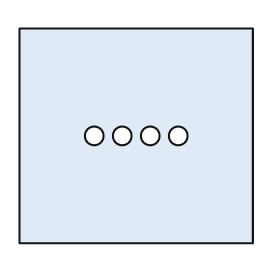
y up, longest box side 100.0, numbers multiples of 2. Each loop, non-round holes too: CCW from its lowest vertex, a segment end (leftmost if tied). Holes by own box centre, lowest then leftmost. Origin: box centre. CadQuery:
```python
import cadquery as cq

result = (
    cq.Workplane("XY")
    .moveTo(-50.0, -46.0)
    .lineTo(50.0, -46.0)
    .lineTo(50.0, 46.0)
    .lineTo(-50.0, 46.0)
    .close()
    .moveTo(-18.0, 0.0)
    .circle(4.0)
    .moveTo(-6.0, 0.0)
    .circle(4.0)
    .moveTo(6.0, 0.0)
    .circle(4.0)
    .moveTo(18.0, 0.0)
    .circle(4.0)
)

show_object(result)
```